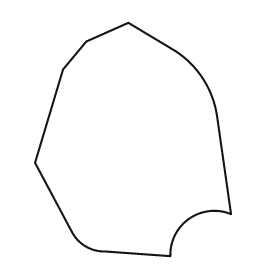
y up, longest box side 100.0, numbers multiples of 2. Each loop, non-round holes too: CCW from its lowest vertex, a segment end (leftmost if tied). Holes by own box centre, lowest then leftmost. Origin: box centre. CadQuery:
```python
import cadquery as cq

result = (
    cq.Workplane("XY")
    .moveTo(16.0, -50.0)
    .threePointArc((24.0, -34.0), (42.0, -32.0))
    .lineTo(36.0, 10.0)
    .threePointArc((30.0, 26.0), (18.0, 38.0))
    .lineTo(-2.0, 50.0)
    .lineTo(-20.0, 42.0)
    .lineTo(-30.0, 30.0)
    .lineTo(-42.0, -10.0)
    .lineTo(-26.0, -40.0)
    .threePointArc((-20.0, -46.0), (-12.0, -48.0))
    .close()
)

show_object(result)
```